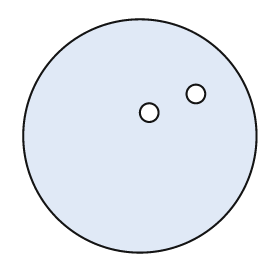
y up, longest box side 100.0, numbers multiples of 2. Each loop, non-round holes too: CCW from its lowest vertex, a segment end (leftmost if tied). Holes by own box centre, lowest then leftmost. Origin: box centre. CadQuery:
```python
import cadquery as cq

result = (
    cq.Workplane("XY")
    .moveTo(0.0, 0.0)
    .circle(50.0)
    .moveTo(4.0, 10.0)
    .circle(4.0)
    .moveTo(24.0, 18.0)
    .circle(4.0)
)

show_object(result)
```